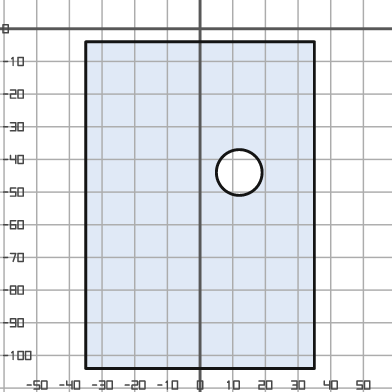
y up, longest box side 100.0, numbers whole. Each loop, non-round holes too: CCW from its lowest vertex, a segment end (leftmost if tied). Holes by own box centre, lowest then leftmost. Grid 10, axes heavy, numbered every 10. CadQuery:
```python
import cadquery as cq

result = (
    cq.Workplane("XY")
    .moveTo(-35.0, -104.0)
    .lineTo(35.0, -104.0)
    .lineTo(35.0, -4.0)
    .lineTo(-35.0, -4.0)
    .close()
    .moveTo(12.0, -44.0)
    .circle(7.0)
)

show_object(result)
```